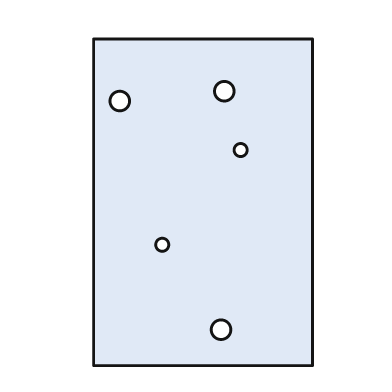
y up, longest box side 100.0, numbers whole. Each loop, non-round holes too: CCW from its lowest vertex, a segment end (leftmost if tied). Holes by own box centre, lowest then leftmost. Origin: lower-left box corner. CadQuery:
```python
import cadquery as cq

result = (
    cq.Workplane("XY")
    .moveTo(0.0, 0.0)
    .lineTo(67.0, 0.0)
    .lineTo(67.0, 100.0)
    .lineTo(0.0, 100.0)
    .close()
    .moveTo(39.0, 11.0)
    .circle(3.0)
    .moveTo(21.0, 37.0)
    .circle(2.0)
    .moveTo(45.0, 66.0)
    .circle(2.0)
    .moveTo(8.0, 81.0)
    .circle(3.0)
    .moveTo(40.0, 84.0)
    .circle(3.0)
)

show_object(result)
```